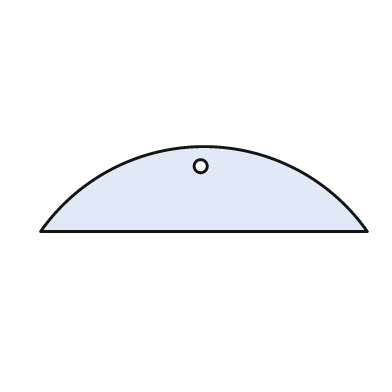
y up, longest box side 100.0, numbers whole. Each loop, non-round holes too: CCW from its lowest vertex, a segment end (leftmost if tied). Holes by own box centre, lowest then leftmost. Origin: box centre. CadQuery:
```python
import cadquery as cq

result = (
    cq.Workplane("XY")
    .moveTo(-50.0, -13.0)
    .lineTo(50.0, -13.0)
    .threePointArc((0.0, 13.0), (-50.0, -13.0))
    .close()
    .moveTo(-1.0, 7.0)
    .circle(2.0)
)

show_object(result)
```